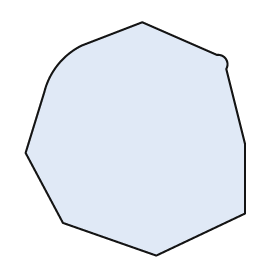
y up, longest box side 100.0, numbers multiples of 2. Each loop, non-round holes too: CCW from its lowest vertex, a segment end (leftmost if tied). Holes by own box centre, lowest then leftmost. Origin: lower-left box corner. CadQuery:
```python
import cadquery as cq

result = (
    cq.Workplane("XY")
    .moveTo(56.0, 0.0)
    .lineTo(94.0, 18.0)
    .lineTo(94.0, 48.0)
    .lineTo(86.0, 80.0)
    .threePointArc((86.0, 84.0), (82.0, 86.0))
    .lineTo(50.0, 100.0)
    .lineTo(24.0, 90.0)
    .threePointArc((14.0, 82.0), (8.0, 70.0))
    .lineTo(0.0, 44.0)
    .lineTo(16.0, 14.0)
    .close()
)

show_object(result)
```